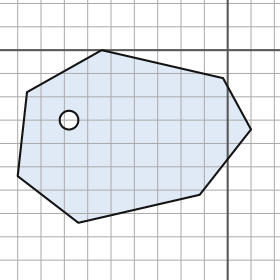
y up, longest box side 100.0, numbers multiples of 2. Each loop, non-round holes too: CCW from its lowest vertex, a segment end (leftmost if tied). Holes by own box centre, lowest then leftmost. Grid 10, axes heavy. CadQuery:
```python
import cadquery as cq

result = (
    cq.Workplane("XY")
    .moveTo(-64.0, -74.0)
    .lineTo(-12.0, -62.0)
    .lineTo(10.0, -34.0)
    .lineTo(-2.0, -12.0)
    .lineTo(-54.0, 0.0)
    .lineTo(-86.0, -18.0)
    .lineTo(-90.0, -54.0)
    .close()
    .moveTo(-68.0, -30.0)
    .circle(4.0)
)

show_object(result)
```